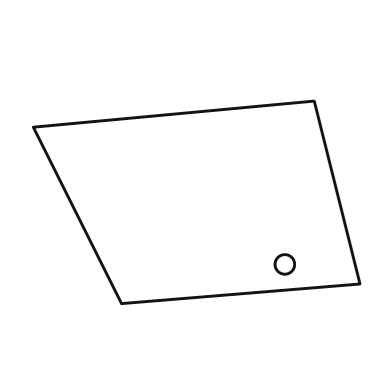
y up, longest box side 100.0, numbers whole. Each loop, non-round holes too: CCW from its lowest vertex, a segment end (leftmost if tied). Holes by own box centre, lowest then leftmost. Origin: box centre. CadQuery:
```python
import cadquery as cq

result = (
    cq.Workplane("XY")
    .moveTo(-23.0, -31.0)
    .lineTo(50.0, -25.0)
    .lineTo(36.0, 31.0)
    .lineTo(-50.0, 23.0)
    .close()
    .moveTo(27.0, -19.0)
    .circle(3.0)
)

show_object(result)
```